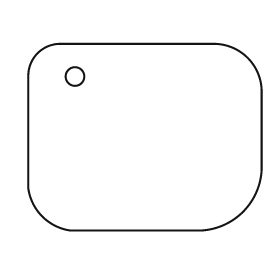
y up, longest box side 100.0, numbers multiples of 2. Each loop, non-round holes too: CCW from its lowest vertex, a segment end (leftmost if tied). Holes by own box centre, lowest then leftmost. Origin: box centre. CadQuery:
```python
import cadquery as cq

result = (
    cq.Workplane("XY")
    .moveTo(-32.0, -40.0)
    .lineTo(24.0, -40.0)
    .threePointArc((42.0, -32.0), (50.0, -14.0))
    .lineTo(50.0, 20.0)
    .threePointArc((44.0, 34.0), (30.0, 40.0))
    .lineTo(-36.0, 40.0)
    .threePointArc((-46.0, 36.0), (-50.0, 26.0))
    .lineTo(-50.0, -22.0)
    .threePointArc((-44.0, -34.0), (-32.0, -40.0))
    .close()
    .moveTo(-30.0, 26.0)
    .circle(4.0)
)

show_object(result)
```